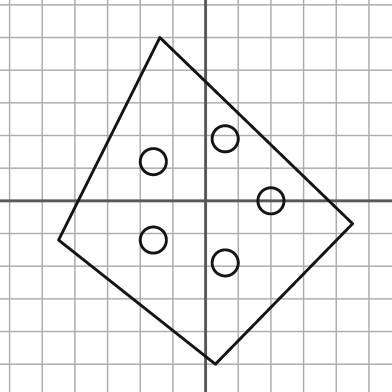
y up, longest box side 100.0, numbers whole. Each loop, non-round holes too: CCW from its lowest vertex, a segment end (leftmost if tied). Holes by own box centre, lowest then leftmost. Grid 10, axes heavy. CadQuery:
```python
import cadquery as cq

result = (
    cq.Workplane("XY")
    .moveTo(3.0, -50.0)
    .lineTo(45.0, -7.0)
    .lineTo(-14.0, 50.0)
    .lineTo(-45.0, -12.0)
    .close()
    .moveTo(6.0, -19.0)
    .circle(4.0)
    .moveTo(-16.0, -12.0)
    .circle(4.0)
    .moveTo(20.0, 0.0)
    .circle(4.0)
    .moveTo(-16.0, 12.0)
    .circle(4.0)
    .moveTo(6.0, 19.0)
    .circle(4.0)
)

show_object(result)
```